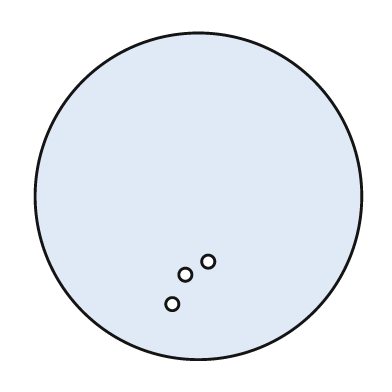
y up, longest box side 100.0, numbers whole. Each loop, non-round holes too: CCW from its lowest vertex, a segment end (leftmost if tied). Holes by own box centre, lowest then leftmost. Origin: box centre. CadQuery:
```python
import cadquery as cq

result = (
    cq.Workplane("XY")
    .moveTo(0.0, 0.0)
    .circle(50.0)
    .moveTo(-8.0, -33.0)
    .circle(2.0)
    .moveTo(-4.0, -24.0)
    .circle(2.0)
    .moveTo(3.0, -20.0)
    .circle(2.0)
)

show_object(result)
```